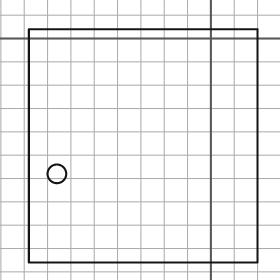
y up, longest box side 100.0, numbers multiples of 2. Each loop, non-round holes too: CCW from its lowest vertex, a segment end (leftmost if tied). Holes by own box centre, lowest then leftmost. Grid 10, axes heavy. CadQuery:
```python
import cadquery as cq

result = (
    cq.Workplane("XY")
    .moveTo(-78.0, -96.0)
    .lineTo(20.0, -96.0)
    .lineTo(20.0, 4.0)
    .lineTo(-78.0, 4.0)
    .close()
    .moveTo(-66.0, -58.0)
    .circle(4.0)
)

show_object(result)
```